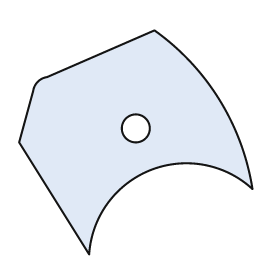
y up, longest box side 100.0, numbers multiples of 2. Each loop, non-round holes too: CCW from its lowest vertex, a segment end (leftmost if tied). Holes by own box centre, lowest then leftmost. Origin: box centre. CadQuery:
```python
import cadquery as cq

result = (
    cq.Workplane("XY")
    .moveTo(-20.0, -48.0)
    .threePointArc((6.0, -12.0), (50.0, -20.0))
    .threePointArc((36.0, 18.0), (8.0, 48.0))
    .lineTo(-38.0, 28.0)
    .threePointArc((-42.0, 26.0), (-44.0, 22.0))
    .lineTo(-50.0, 0.0)
    .close()
    .moveTo(0.0, 6.0)
    .circle(6.0)
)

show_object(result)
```